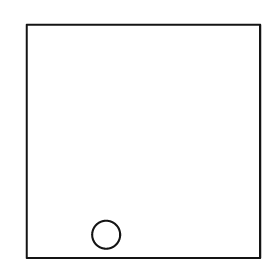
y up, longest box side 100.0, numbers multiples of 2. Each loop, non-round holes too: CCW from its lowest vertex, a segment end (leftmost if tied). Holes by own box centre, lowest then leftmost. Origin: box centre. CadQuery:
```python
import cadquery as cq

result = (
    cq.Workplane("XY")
    .moveTo(-50.0, -50.0)
    .lineTo(50.0, -50.0)
    .lineTo(50.0, 50.0)
    .lineTo(-50.0, 50.0)
    .close()
    .moveTo(-16.0, -40.0)
    .circle(6.0)
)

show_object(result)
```